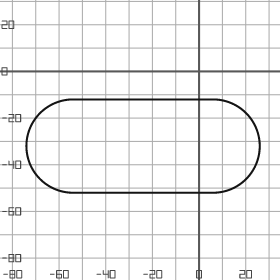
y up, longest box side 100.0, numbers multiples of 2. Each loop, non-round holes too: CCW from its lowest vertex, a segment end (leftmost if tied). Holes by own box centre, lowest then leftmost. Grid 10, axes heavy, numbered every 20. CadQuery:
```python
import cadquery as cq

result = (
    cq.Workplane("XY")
    .moveTo(-54.0, -52.0)
    .lineTo(6.0, -52.0)
    .threePointArc((26.0, -32.0), (6.0, -12.0))
    .lineTo(-54.0, -12.0)
    .threePointArc((-74.0, -32.0), (-54.0, -52.0))
    .close()
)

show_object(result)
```